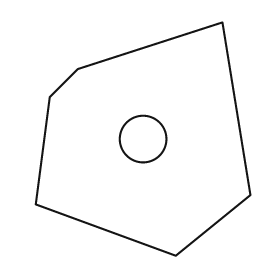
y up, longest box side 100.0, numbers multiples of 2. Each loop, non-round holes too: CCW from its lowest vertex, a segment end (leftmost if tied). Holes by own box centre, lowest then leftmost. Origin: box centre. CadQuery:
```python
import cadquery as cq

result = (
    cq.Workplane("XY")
    .moveTo(14.0, -50.0)
    .lineTo(46.0, -24.0)
    .lineTo(34.0, 50.0)
    .lineTo(-28.0, 30.0)
    .lineTo(-40.0, 18.0)
    .lineTo(-46.0, -28.0)
    .close()
    .moveTo(0.0, 0.0)
    .circle(10.0)
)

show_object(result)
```